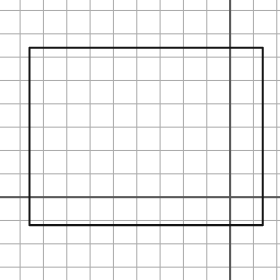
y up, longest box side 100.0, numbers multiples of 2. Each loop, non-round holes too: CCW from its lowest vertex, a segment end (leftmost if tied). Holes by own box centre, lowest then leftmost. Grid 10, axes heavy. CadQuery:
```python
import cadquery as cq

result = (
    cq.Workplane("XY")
    .moveTo(-86.0, -12.0)
    .lineTo(14.0, -12.0)
    .lineTo(14.0, 64.0)
    .lineTo(-86.0, 64.0)
    .close()
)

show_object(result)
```